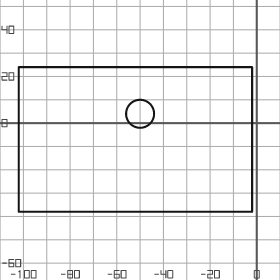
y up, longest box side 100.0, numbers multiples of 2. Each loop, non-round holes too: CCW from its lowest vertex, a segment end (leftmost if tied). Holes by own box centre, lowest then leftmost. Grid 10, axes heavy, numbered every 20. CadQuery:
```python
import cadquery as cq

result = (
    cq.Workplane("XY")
    .moveTo(-102.0, -38.0)
    .lineTo(-2.0, -38.0)
    .lineTo(-2.0, 24.0)
    .lineTo(-102.0, 24.0)
    .close()
    .moveTo(-50.0, 4.0)
    .circle(6.0)
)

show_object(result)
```